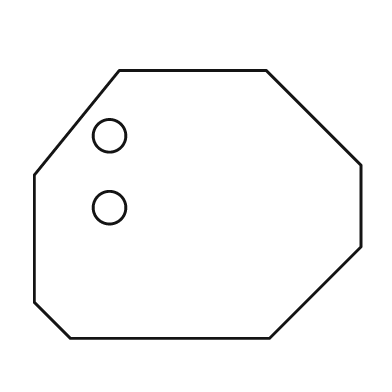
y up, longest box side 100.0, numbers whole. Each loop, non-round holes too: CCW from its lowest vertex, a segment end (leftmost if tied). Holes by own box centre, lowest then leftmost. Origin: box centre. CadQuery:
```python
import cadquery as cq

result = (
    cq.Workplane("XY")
    .moveTo(-39.0, -41.0)
    .lineTo(22.0, -41.0)
    .lineTo(50.0, -13.0)
    .lineTo(50.0, 12.0)
    .lineTo(21.0, 41.0)
    .lineTo(-24.0, 41.0)
    .lineTo(-50.0, 9.0)
    .lineTo(-50.0, -30.0)
    .close()
    .moveTo(-27.0, -1.0)
    .circle(5.0)
    .moveTo(-27.0, 21.0)
    .circle(5.0)
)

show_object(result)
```